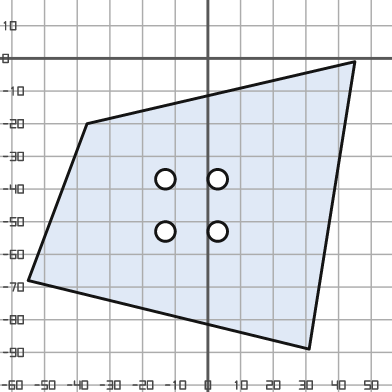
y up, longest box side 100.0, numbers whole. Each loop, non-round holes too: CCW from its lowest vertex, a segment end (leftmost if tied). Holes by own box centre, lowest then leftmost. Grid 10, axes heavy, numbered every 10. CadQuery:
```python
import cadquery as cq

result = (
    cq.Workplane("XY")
    .moveTo(31.0, -89.0)
    .lineTo(45.0, -1.0)
    .lineTo(-37.0, -20.0)
    .lineTo(-55.0, -68.0)
    .close()
    .moveTo(-13.0, -53.0)
    .circle(3.0)
    .moveTo(3.0, -53.0)
    .circle(3.0)
    .moveTo(-13.0, -37.0)
    .circle(3.0)
    .moveTo(3.0, -37.0)
    .circle(3.0)
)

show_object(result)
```